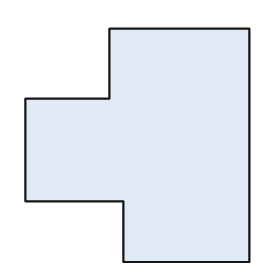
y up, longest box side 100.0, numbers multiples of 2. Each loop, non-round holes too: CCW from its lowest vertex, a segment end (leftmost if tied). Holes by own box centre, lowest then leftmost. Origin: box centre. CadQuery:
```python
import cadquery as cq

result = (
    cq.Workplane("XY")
    .moveTo(-6.0, -50.0)
    .lineTo(48.0, -50.0)
    .lineTo(48.0, 50.0)
    .lineTo(-12.0, 50.0)
    .lineTo(-12.0, 20.0)
    .lineTo(-48.0, 20.0)
    .lineTo(-48.0, -24.0)
    .lineTo(-6.0, -24.0)
    .close()
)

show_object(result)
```